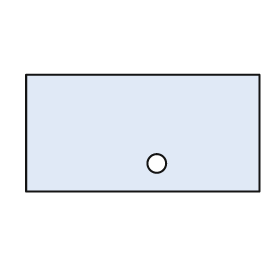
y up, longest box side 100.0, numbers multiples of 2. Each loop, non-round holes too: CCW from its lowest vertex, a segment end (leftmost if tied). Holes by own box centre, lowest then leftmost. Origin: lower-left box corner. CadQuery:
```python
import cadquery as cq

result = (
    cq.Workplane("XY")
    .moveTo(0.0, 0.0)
    .lineTo(100.0, 0.0)
    .lineTo(100.0, 50.0)
    .lineTo(0.0, 50.0)
    .close()
    .moveTo(56.0, 12.0)
    .circle(4.0)
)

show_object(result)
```